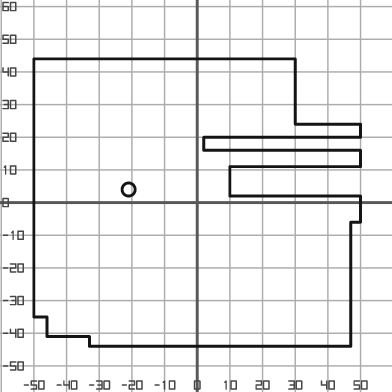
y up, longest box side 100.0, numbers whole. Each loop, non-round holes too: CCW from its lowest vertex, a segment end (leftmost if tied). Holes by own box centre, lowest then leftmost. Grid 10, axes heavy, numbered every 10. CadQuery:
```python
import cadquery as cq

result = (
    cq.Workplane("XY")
    .moveTo(-33.0, -44.0)
    .lineTo(47.0, -44.0)
    .lineTo(47.0, -6.0)
    .lineTo(50.0, -6.0)
    .lineTo(50.0, 2.0)
    .lineTo(10.0, 2.0)
    .lineTo(10.0, 11.0)
    .lineTo(50.0, 11.0)
    .lineTo(50.0, 16.0)
    .lineTo(2.0, 16.0)
    .lineTo(2.0, 20.0)
    .lineTo(50.0, 20.0)
    .lineTo(50.0, 24.0)
    .lineTo(30.0, 24.0)
    .lineTo(30.0, 44.0)
    .lineTo(-50.0, 44.0)
    .lineTo(-50.0, -35.0)
    .lineTo(-46.0, -35.0)
    .lineTo(-46.0, -41.0)
    .lineTo(-33.0, -41.0)
    .close()
    .moveTo(-21.0, 4.0)
    .circle(2.0)
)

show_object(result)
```